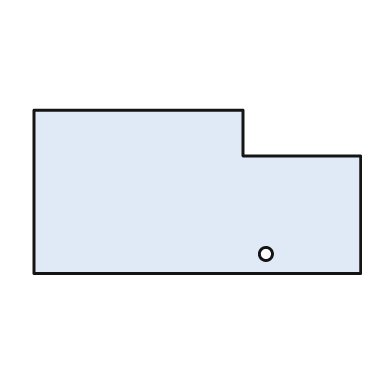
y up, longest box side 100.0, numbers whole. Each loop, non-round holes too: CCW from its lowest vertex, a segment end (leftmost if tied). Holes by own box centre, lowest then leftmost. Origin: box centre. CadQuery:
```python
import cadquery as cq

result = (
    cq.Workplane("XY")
    .moveTo(-50.0, -25.0)
    .lineTo(50.0, -25.0)
    .lineTo(50.0, 11.0)
    .lineTo(14.0, 11.0)
    .lineTo(14.0, 25.0)
    .lineTo(-50.0, 25.0)
    .close()
    .moveTo(21.0, -19.0)
    .circle(2.0)
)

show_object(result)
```